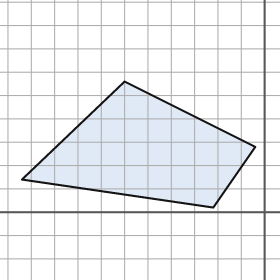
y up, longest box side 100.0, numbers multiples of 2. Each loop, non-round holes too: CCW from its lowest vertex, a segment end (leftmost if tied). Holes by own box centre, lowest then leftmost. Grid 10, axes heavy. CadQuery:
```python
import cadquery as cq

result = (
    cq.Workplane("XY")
    .moveTo(-22.0, 2.0)
    .lineTo(-4.0, 28.0)
    .lineTo(-60.0, 56.0)
    .lineTo(-104.0, 14.0)
    .close()
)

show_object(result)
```